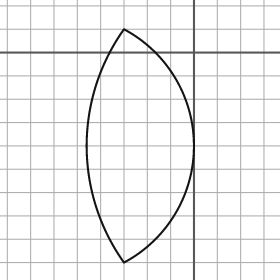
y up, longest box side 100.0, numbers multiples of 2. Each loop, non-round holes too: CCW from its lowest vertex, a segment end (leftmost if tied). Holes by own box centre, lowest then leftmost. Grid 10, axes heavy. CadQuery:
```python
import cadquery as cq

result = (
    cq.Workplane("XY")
    .moveTo(-30.0, -90.0)
    .threePointArc((0.0, -40.0), (-30.0, 10.0))
    .threePointArc((-46.0, -40.0), (-30.0, -90.0))
    .close()
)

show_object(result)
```